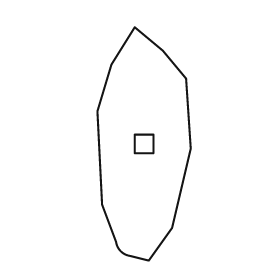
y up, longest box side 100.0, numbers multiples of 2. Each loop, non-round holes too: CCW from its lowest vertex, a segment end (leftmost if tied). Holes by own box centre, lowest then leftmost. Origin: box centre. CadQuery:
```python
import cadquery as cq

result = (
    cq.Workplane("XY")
    .moveTo(2.0, -50.0)
    .lineTo(12.0, -36.0)
    .lineTo(20.0, -2.0)
    .lineTo(18.0, 28.0)
    .lineTo(8.0, 40.0)
    .lineTo(-4.0, 50.0)
    .lineTo(-14.0, 34.0)
    .lineTo(-20.0, 14.0)
    .lineTo(-18.0, -26.0)
    .lineTo(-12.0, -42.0)
    .threePointArc((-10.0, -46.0), (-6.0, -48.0))
    .close()
    .moveTo(-4.0, -4.0)
    .lineTo(4.0, -4.0)
    .lineTo(4.0, 4.0)
    .lineTo(-4.0, 4.0)
    .close()
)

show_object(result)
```